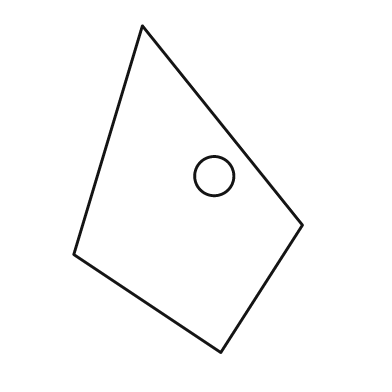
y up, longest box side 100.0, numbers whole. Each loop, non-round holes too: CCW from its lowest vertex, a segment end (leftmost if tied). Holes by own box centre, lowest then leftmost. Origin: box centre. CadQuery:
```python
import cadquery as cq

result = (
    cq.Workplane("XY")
    .moveTo(10.0, -50.0)
    .lineTo(35.0, -11.0)
    .lineTo(-14.0, 50.0)
    .lineTo(-35.0, -20.0)
    .close()
    .moveTo(8.0, 4.0)
    .circle(6.0)
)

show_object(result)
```